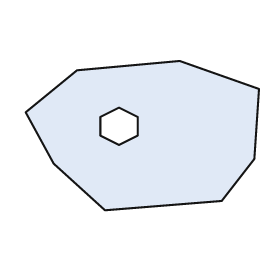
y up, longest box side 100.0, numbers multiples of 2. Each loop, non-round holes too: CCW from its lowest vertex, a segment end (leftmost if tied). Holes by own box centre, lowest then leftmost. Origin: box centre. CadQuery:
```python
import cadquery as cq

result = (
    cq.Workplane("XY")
    .moveTo(-16.0, -32.0)
    .lineTo(34.0, -28.0)
    .lineTo(48.0, -10.0)
    .lineTo(50.0, 20.0)
    .lineTo(16.0, 32.0)
    .lineTo(-28.0, 28.0)
    .lineTo(-50.0, 10.0)
    .lineTo(-38.0, -12.0)
    .close()
    .moveTo(-10.0, -4.0)
    .lineTo(-2.0, 0.0)
    .lineTo(-2.0, 8.0)
    .lineTo(-10.0, 12.0)
    .lineTo(-18.0, 8.0)
    .lineTo(-18.0, 0.0)
    .close()
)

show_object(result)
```